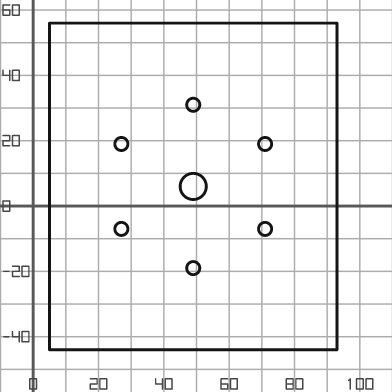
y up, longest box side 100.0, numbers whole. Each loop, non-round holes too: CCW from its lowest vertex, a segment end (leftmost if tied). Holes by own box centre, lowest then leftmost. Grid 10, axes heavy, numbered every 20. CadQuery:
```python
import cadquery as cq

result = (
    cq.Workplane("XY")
    .moveTo(5.0, -44.0)
    .lineTo(93.0, -44.0)
    .lineTo(93.0, 56.0)
    .lineTo(5.0, 56.0)
    .close()
    .moveTo(49.0, -19.0)
    .circle(2.0)
    .moveTo(27.0, -7.0)
    .circle(2.0)
    .moveTo(71.0, -7.0)
    .circle(2.0)
    .moveTo(49.0, 6.0)
    .circle(4.0)
    .moveTo(27.0, 19.0)
    .circle(2.0)
    .moveTo(71.0, 19.0)
    .circle(2.0)
    .moveTo(49.0, 31.0)
    .circle(2.0)
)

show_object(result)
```